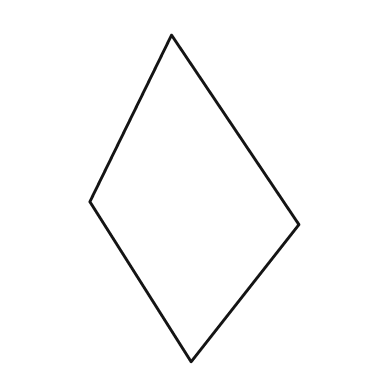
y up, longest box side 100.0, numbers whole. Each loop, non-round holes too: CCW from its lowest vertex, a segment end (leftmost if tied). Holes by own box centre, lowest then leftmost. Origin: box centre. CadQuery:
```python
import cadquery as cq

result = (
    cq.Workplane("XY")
    .moveTo(-1.0, -50.0)
    .lineTo(32.0, -8.0)
    .lineTo(-7.0, 50.0)
    .lineTo(-32.0, -1.0)
    .close()
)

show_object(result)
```